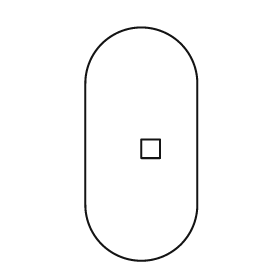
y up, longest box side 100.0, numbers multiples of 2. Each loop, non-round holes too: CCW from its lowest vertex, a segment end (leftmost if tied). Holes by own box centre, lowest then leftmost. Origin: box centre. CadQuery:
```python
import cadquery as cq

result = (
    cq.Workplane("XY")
    .moveTo(-24.0, -26.0)
    .threePointArc((0.0, -50.0), (24.0, -26.0))
    .lineTo(24.0, 26.0)
    .threePointArc((0.0, 50.0), (-24.0, 26.0))
    .close()
    .moveTo(0.0, -6.0)
    .lineTo(8.0, -6.0)
    .lineTo(8.0, 2.0)
    .lineTo(0.0, 2.0)
    .close()
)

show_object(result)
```